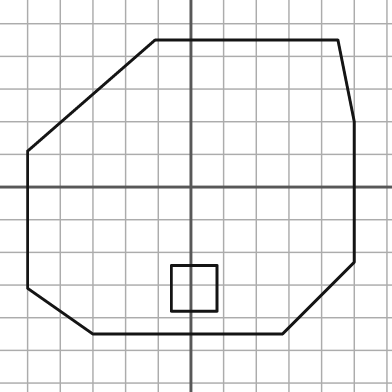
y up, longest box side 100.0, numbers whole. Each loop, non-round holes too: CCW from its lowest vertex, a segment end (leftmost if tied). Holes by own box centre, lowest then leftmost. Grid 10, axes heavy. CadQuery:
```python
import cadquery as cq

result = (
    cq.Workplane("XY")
    .moveTo(-30.0, -45.0)
    .lineTo(28.0, -45.0)
    .lineTo(50.0, -23.0)
    .lineTo(50.0, 20.0)
    .lineTo(45.0, 45.0)
    .lineTo(-11.0, 45.0)
    .lineTo(-50.0, 11.0)
    .lineTo(-50.0, -31.0)
    .close()
    .moveTo(-6.0, -38.0)
    .lineTo(8.0, -38.0)
    .lineTo(8.0, -24.0)
    .lineTo(-6.0, -24.0)
    .close()
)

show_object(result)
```